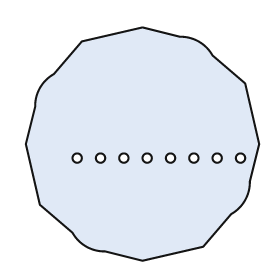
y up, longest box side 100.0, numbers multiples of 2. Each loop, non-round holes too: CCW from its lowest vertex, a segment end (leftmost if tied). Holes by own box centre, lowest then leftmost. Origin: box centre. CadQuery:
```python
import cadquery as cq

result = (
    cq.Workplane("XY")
    .moveTo(0.0, -50.0)
    .lineTo(26.0, -44.0)
    .lineTo(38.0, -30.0)
    .threePointArc((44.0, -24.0), (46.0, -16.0))
    .lineTo(50.0, 0.0)
    .lineTo(44.0, 26.0)
    .lineTo(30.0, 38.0)
    .threePointArc((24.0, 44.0), (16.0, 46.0))
    .lineTo(0.0, 50.0)
    .lineTo(-26.0, 44.0)
    .lineTo(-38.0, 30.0)
    .threePointArc((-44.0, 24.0), (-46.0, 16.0))
    .lineTo(-50.0, 0.0)
    .lineTo(-44.0, -26.0)
    .lineTo(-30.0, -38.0)
    .threePointArc((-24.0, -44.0), (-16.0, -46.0))
    .close()
    .moveTo(-28.0, -6.0)
    .circle(2.0)
    .moveTo(-18.0, -6.0)
    .circle(2.0)
    .moveTo(-8.0, -6.0)
    .circle(2.0)
    .moveTo(2.0, -6.0)
    .circle(2.0)
    .moveTo(12.0, -6.0)
    .circle(2.0)
    .moveTo(22.0, -6.0)
    .circle(2.0)
    .moveTo(32.0, -6.0)
    .circle(2.0)
    .moveTo(42.0, -6.0)
    .circle(2.0)
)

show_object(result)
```